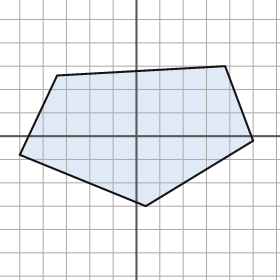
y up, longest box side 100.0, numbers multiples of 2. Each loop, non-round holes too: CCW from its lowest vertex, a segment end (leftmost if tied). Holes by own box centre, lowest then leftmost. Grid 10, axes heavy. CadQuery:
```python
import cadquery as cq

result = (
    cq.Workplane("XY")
    .moveTo(4.0, -30.0)
    .lineTo(50.0, -2.0)
    .lineTo(38.0, 30.0)
    .lineTo(-34.0, 26.0)
    .lineTo(-50.0, -8.0)
    .close()
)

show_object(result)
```